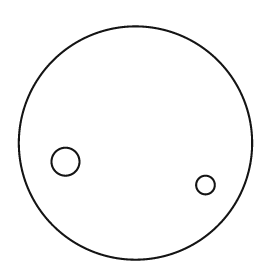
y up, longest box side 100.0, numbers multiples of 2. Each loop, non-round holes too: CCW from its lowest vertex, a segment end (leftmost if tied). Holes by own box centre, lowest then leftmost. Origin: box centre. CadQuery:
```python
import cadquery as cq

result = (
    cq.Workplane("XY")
    .moveTo(0.0, 0.0)
    .circle(50.0)
    .moveTo(30.0, -18.0)
    .circle(4.0)
    .moveTo(-30.0, -8.0)
    .circle(6.0)
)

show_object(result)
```